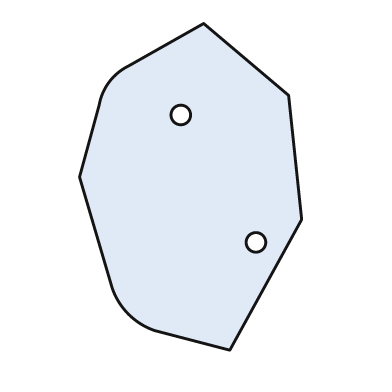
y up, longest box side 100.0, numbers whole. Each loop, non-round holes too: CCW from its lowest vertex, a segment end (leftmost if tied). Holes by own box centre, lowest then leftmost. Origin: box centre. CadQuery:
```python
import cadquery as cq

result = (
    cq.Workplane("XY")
    .moveTo(12.0, -50.0)
    .lineTo(34.0, -10.0)
    .lineTo(30.0, 28.0)
    .lineTo(4.0, 50.0)
    .lineTo(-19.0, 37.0)
    .threePointArc((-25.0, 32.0), (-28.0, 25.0))
    .lineTo(-34.0, 3.0)
    .lineTo(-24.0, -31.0)
    .threePointArc((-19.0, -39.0), (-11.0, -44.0))
    .close()
    .moveTo(20.0, -17.0)
    .circle(3.0)
    .moveTo(-3.0, 22.0)
    .circle(3.0)
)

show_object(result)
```